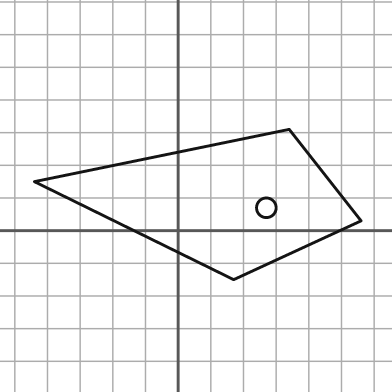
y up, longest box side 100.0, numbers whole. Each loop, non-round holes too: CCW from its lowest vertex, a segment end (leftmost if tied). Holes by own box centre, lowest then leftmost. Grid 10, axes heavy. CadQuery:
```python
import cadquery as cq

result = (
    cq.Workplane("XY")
    .moveTo(17.0, -15.0)
    .lineTo(56.0, 3.0)
    .lineTo(34.0, 31.0)
    .lineTo(-44.0, 15.0)
    .close()
    .moveTo(27.0, 7.0)
    .circle(3.0)
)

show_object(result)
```